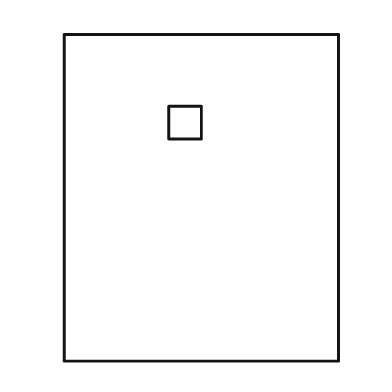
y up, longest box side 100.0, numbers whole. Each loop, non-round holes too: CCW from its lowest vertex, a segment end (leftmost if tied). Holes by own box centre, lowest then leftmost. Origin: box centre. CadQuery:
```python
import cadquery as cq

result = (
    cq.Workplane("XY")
    .moveTo(-42.0, -50.0)
    .lineTo(42.0, -50.0)
    .lineTo(42.0, 50.0)
    .lineTo(-42.0, 50.0)
    .close()
    .moveTo(-10.0, 18.0)
    .lineTo(0.0, 18.0)
    .lineTo(0.0, 28.0)
    .lineTo(-10.0, 28.0)
    .close()
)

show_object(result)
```